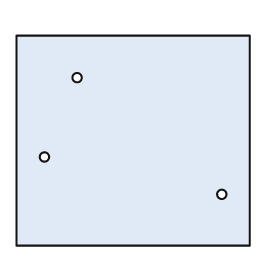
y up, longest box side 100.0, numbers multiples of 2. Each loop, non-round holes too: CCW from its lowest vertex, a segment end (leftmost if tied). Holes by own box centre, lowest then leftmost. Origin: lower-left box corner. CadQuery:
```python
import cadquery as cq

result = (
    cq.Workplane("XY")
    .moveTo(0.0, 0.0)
    .lineTo(100.0, 0.0)
    .lineTo(100.0, 90.0)
    .lineTo(0.0, 90.0)
    .close()
    .moveTo(88.0, 22.0)
    .circle(2.0)
    .moveTo(12.0, 38.0)
    .circle(2.0)
    .moveTo(26.0, 72.0)
    .circle(2.0)
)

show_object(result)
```